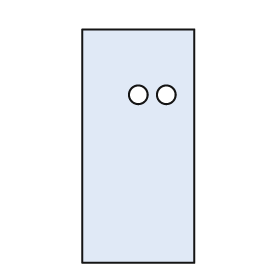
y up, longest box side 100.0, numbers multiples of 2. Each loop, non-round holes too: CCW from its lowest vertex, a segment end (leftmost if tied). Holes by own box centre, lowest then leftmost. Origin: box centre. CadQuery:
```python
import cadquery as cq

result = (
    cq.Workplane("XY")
    .moveTo(-24.0, -50.0)
    .lineTo(24.0, -50.0)
    .lineTo(24.0, 50.0)
    .lineTo(-24.0, 50.0)
    .close()
    .moveTo(0.0, 22.0)
    .circle(4.0)
    .moveTo(12.0, 22.0)
    .circle(4.0)
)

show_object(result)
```